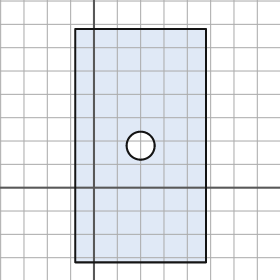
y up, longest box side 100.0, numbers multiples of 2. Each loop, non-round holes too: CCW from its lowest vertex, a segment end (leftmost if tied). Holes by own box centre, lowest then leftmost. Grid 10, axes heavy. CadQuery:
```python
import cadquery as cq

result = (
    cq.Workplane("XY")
    .moveTo(-8.0, -32.0)
    .lineTo(48.0, -32.0)
    .lineTo(48.0, 68.0)
    .lineTo(-8.0, 68.0)
    .close()
    .moveTo(20.0, 18.0)
    .circle(6.0)
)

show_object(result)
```